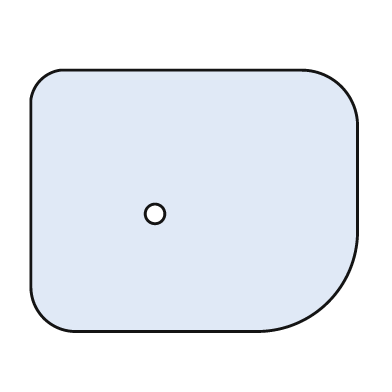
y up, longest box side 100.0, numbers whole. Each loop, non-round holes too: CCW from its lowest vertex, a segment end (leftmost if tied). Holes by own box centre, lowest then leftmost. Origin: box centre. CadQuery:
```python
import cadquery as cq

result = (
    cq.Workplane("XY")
    .moveTo(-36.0, -40.0)
    .lineTo(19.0, -40.0)
    .threePointArc((41.0, -31.0), (50.0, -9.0))
    .lineTo(50.0, 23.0)
    .threePointArc((45.0, 35.0), (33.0, 40.0))
    .lineTo(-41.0, 40.0)
    .threePointArc((-47.0, 37.0), (-50.0, 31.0))
    .lineTo(-50.0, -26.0)
    .threePointArc((-46.0, -36.0), (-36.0, -40.0))
    .close()
    .moveTo(-12.0, -4.0)
    .circle(3.0)
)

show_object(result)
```